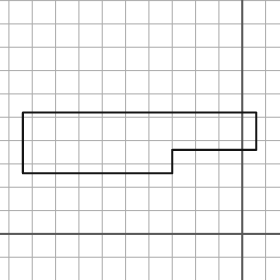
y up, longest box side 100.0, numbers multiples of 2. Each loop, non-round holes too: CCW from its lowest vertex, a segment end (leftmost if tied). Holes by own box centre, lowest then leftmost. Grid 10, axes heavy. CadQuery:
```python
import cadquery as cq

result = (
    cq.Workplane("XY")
    .moveTo(-94.0, 26.0)
    .lineTo(-30.0, 26.0)
    .lineTo(-30.0, 36.0)
    .lineTo(6.0, 36.0)
    .lineTo(6.0, 52.0)
    .lineTo(-94.0, 52.0)
    .close()
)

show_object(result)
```